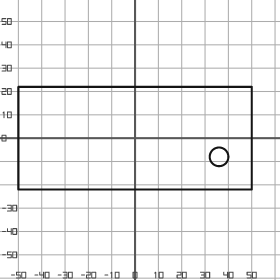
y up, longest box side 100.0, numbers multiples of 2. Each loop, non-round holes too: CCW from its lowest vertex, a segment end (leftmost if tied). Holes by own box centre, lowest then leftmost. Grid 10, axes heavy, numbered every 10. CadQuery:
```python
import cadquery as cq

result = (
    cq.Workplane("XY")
    .moveTo(-50.0, -22.0)
    .lineTo(50.0, -22.0)
    .lineTo(50.0, 22.0)
    .lineTo(-50.0, 22.0)
    .close()
    .moveTo(36.0, -8.0)
    .circle(4.0)
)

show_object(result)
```